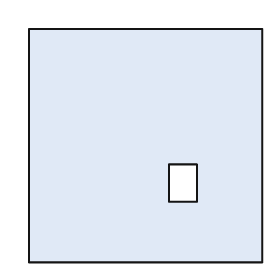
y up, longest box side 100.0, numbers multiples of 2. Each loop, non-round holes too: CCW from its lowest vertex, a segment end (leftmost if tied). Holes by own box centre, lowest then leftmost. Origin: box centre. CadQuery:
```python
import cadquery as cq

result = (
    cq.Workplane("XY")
    .moveTo(-50.0, -50.0)
    .lineTo(50.0, -50.0)
    .lineTo(50.0, 50.0)
    .lineTo(-50.0, 50.0)
    .close()
    .moveTo(10.0, -24.0)
    .lineTo(22.0, -24.0)
    .lineTo(22.0, -8.0)
    .lineTo(10.0, -8.0)
    .close()
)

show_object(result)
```